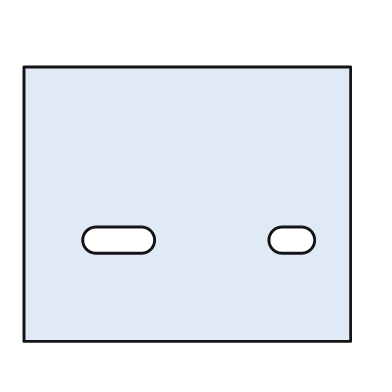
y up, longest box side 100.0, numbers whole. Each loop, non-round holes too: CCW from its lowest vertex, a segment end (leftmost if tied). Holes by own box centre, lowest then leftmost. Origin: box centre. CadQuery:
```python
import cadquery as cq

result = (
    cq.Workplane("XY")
    .moveTo(-50.0, -42.0)
    .lineTo(50.0, -42.0)
    .lineTo(50.0, 42.0)
    .lineTo(-50.0, 42.0)
    .close()
    .moveTo(-28.0, -15.0)
    .lineTo(-14.0, -15.0)
    .threePointArc((-10.0, -11.0), (-14.0, -7.0))
    .lineTo(-28.0, -7.0)
    .threePointArc((-32.0, -11.0), (-28.0, -15.0))
    .close()
    .moveTo(29.0, -15.0)
    .lineTo(35.0, -15.0)
    .threePointArc((39.0, -11.0), (35.0, -7.0))
    .lineTo(29.0, -7.0)
    .threePointArc((25.0, -11.0), (29.0, -15.0))
    .close()
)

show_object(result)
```